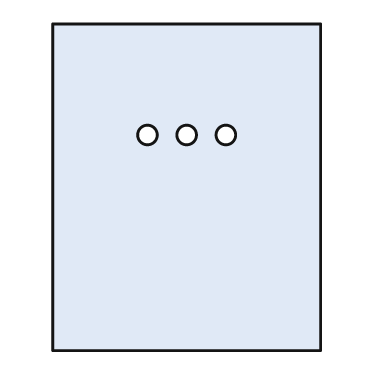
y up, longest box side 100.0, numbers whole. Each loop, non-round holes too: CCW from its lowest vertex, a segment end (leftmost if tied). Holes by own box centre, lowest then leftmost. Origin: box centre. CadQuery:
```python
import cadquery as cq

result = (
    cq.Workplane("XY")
    .moveTo(-41.0, -50.0)
    .lineTo(41.0, -50.0)
    .lineTo(41.0, 50.0)
    .lineTo(-41.0, 50.0)
    .close()
    .moveTo(-12.0, 16.0)
    .circle(3.0)
    .moveTo(0.0, 16.0)
    .circle(3.0)
    .moveTo(12.0, 16.0)
    .circle(3.0)
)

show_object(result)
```